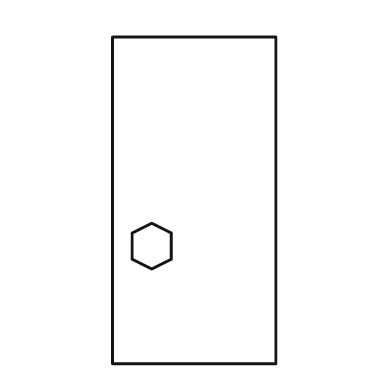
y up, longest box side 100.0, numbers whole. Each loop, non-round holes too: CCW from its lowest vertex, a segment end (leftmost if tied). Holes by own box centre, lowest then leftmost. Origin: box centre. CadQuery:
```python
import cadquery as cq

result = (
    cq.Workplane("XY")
    .moveTo(-25.0, -50.0)
    .lineTo(25.0, -50.0)
    .lineTo(25.0, 50.0)
    .lineTo(-25.0, 50.0)
    .close()
    .moveTo(-13.0, -21.0)
    .lineTo(-7.0, -18.0)
    .lineTo(-7.0, -10.0)
    .lineTo(-13.0, -7.0)
    .lineTo(-19.0, -10.0)
    .lineTo(-19.0, -18.0)
    .close()
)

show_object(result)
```